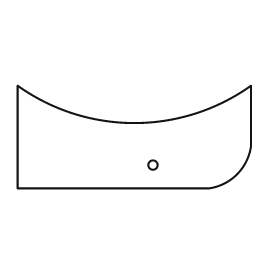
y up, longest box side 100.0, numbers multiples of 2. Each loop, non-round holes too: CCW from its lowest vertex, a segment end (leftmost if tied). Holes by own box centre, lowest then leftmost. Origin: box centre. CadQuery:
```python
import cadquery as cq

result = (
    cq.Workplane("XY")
    .moveTo(-50.0, -22.0)
    .lineTo(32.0, -22.0)
    .threePointArc((44.0, -16.0), (50.0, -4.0))
    .lineTo(50.0, 22.0)
    .threePointArc((0.0, 6.0), (-50.0, 22.0))
    .close()
    .moveTo(8.0, -12.0)
    .circle(2.0)
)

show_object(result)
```